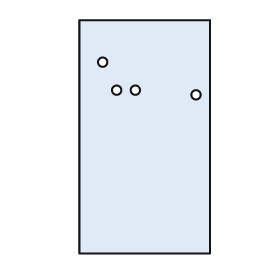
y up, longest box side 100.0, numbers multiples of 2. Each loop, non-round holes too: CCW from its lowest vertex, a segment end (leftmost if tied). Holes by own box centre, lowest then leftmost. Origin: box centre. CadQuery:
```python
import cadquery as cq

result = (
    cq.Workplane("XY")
    .moveTo(-28.0, -50.0)
    .lineTo(28.0, -50.0)
    .lineTo(28.0, 50.0)
    .lineTo(-28.0, 50.0)
    .close()
    .moveTo(22.0, 18.0)
    .circle(2.0)
    .moveTo(-12.0, 20.0)
    .circle(2.0)
    .moveTo(-4.0, 20.0)
    .circle(2.0)
    .moveTo(-18.0, 32.0)
    .circle(2.0)
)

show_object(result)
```